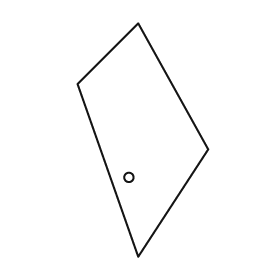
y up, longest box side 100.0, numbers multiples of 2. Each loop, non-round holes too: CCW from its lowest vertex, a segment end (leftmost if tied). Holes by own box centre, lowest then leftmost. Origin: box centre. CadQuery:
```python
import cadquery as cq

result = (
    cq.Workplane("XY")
    .moveTo(-2.0, -50.0)
    .lineTo(28.0, -4.0)
    .lineTo(-2.0, 50.0)
    .lineTo(-28.0, 24.0)
    .close()
    .moveTo(-6.0, -16.0)
    .circle(2.0)
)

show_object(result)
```